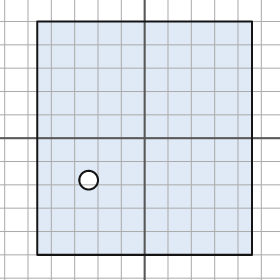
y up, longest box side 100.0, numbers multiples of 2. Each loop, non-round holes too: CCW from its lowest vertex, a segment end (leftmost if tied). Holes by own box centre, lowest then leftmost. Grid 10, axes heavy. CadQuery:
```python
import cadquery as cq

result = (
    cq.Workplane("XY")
    .moveTo(-46.0, -50.0)
    .lineTo(46.0, -50.0)
    .lineTo(46.0, 50.0)
    .lineTo(-46.0, 50.0)
    .close()
    .moveTo(-24.0, -18.0)
    .circle(4.0)
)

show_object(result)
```